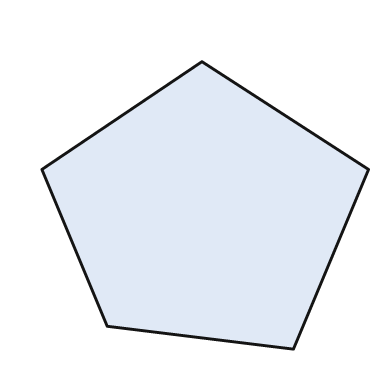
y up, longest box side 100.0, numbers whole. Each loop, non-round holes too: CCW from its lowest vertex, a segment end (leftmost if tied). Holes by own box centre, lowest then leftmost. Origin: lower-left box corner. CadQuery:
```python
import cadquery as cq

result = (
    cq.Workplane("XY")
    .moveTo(77.0, 0.0)
    .lineTo(100.0, 55.0)
    .lineTo(49.0, 88.0)
    .lineTo(0.0, 55.0)
    .lineTo(20.0, 7.0)
    .close()
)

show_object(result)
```